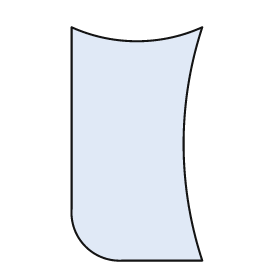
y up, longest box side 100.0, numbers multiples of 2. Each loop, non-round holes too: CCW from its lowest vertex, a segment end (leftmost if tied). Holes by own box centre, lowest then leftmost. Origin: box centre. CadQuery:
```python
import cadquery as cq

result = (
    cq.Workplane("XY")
    .moveTo(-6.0, -50.0)
    .lineTo(28.0, -50.0)
    .threePointArc((20.0, 0.0), (28.0, 50.0))
    .threePointArc((0.0, 44.0), (-28.0, 50.0))
    .lineTo(-28.0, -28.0)
    .threePointArc((-22.0, -44.0), (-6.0, -50.0))
    .close()
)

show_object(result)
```